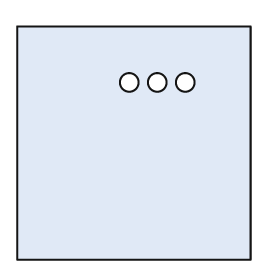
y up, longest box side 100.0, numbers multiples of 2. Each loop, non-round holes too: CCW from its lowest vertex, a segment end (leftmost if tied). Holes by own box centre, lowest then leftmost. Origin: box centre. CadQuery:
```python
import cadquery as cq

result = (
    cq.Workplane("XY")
    .moveTo(-50.0, -50.0)
    .lineTo(50.0, -50.0)
    .lineTo(50.0, 50.0)
    .lineTo(-50.0, 50.0)
    .close()
    .moveTo(-2.0, 26.0)
    .circle(4.0)
    .moveTo(10.0, 26.0)
    .circle(4.0)
    .moveTo(22.0, 26.0)
    .circle(4.0)
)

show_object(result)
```